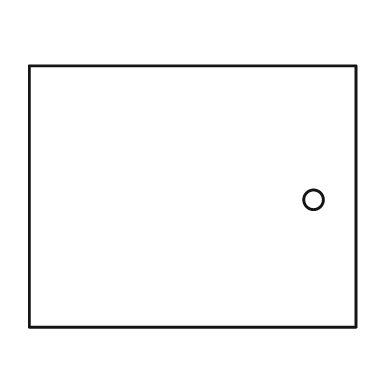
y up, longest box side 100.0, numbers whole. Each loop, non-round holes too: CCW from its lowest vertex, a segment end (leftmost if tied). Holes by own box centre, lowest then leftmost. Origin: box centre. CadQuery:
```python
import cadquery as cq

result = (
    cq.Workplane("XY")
    .moveTo(-50.0, -40.0)
    .lineTo(50.0, -40.0)
    .lineTo(50.0, 40.0)
    .lineTo(-50.0, 40.0)
    .close()
    .moveTo(37.0, -1.0)
    .circle(3.0)
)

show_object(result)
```